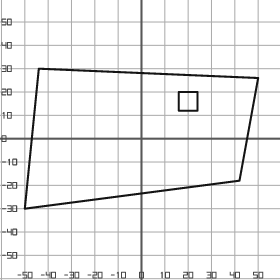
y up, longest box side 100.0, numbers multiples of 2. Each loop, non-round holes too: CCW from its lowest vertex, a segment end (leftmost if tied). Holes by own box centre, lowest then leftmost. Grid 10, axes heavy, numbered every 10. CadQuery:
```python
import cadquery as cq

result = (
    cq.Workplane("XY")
    .moveTo(-50.0, -30.0)
    .lineTo(42.0, -18.0)
    .lineTo(50.0, 26.0)
    .lineTo(-44.0, 30.0)
    .close()
    .moveTo(16.0, 12.0)
    .lineTo(24.0, 12.0)
    .lineTo(24.0, 20.0)
    .lineTo(16.0, 20.0)
    .close()
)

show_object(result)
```